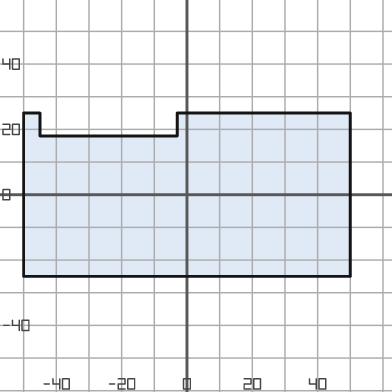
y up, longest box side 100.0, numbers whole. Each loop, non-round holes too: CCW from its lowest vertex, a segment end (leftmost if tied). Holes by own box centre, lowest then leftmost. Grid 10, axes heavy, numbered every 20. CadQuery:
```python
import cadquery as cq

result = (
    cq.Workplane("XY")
    .moveTo(-50.0, -25.0)
    .lineTo(50.0, -25.0)
    .lineTo(50.0, 25.0)
    .lineTo(-3.0, 25.0)
    .lineTo(-3.0, 18.0)
    .lineTo(-45.0, 18.0)
    .lineTo(-45.0, 25.0)
    .lineTo(-50.0, 25.0)
    .close()
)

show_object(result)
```